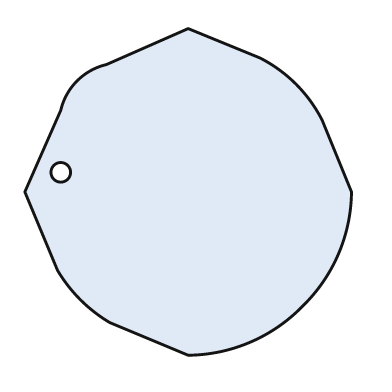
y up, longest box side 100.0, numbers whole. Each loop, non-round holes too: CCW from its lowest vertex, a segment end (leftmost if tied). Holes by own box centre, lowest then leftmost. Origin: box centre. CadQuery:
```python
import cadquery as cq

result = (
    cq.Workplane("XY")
    .moveTo(0.0, -50.0)
    .threePointArc((19.0, -46.0), (35.0, -35.0))
    .threePointArc((46.0, -19.0), (50.0, 0.0))
    .lineTo(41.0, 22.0)
    .threePointArc((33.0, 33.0), (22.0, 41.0))
    .lineTo(0.0, 50.0)
    .lineTo(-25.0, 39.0)
    .threePointArc((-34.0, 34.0), (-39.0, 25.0))
    .lineTo(-50.0, 0.0)
    .lineTo(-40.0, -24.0)
    .threePointArc((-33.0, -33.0), (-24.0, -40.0))
    .close()
    .moveTo(-39.0, 6.0)
    .circle(3.0)
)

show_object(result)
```